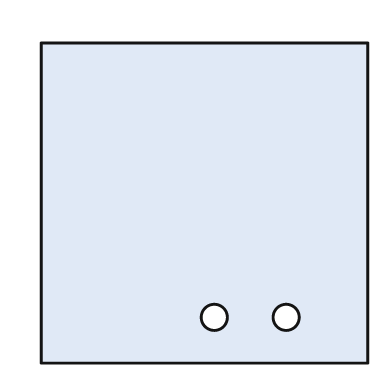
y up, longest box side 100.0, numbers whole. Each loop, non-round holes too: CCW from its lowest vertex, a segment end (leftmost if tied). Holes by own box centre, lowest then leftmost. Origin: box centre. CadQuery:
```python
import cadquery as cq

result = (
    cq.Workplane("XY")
    .moveTo(-50.0, -49.0)
    .lineTo(50.0, -49.0)
    .lineTo(50.0, 49.0)
    .lineTo(-50.0, 49.0)
    .close()
    .moveTo(3.0, -35.0)
    .circle(4.0)
    .moveTo(25.0, -35.0)
    .circle(4.0)
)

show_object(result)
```